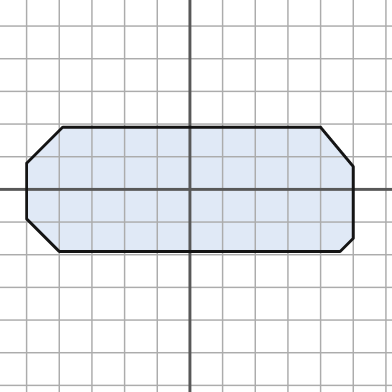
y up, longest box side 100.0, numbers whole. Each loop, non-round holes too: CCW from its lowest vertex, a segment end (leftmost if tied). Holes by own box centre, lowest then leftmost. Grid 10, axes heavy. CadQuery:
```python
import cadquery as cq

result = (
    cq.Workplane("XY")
    .moveTo(-40.0, -19.0)
    .lineTo(46.0, -19.0)
    .lineTo(50.0, -15.0)
    .lineTo(50.0, 7.0)
    .lineTo(40.0, 19.0)
    .lineTo(-39.0, 19.0)
    .lineTo(-50.0, 8.0)
    .lineTo(-50.0, -9.0)
    .close()
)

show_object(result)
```